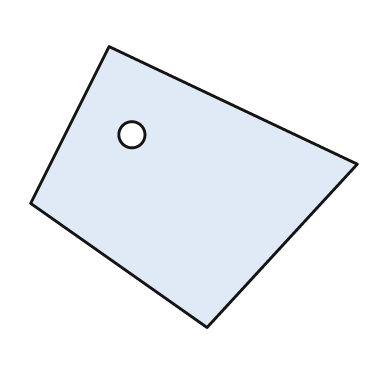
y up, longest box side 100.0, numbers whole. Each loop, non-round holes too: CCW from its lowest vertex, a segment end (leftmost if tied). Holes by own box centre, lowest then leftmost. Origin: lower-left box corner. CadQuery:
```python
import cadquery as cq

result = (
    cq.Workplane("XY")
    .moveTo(54.0, 0.0)
    .lineTo(100.0, 50.0)
    .lineTo(24.0, 86.0)
    .lineTo(0.0, 38.0)
    .close()
    .moveTo(31.0, 59.0)
    .circle(4.0)
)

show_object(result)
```